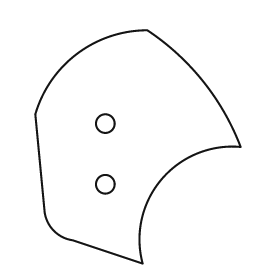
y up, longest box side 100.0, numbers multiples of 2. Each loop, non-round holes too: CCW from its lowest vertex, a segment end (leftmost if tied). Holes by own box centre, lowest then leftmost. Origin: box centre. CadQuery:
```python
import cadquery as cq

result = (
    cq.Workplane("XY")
    .moveTo(2.0, -50.0)
    .threePointArc((10.0, -14.0), (44.0, 0.0))
    .threePointArc((28.0, 28.0), (4.0, 50.0))
    .threePointArc((-26.0, 40.0), (-44.0, 14.0))
    .lineTo(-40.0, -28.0)
    .threePointArc((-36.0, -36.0), (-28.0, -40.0))
    .close()
    .moveTo(-14.0, -16.0)
    .circle(4.0)
    .moveTo(-14.0, 10.0)
    .circle(4.0)
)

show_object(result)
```